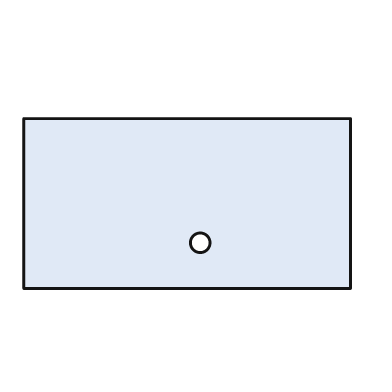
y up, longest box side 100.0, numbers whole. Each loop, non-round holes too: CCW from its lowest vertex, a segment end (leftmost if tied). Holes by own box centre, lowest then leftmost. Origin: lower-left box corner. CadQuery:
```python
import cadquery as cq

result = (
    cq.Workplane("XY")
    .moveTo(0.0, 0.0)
    .lineTo(100.0, 0.0)
    .lineTo(100.0, 52.0)
    .lineTo(0.0, 52.0)
    .close()
    .moveTo(54.0, 14.0)
    .circle(3.0)
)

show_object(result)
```